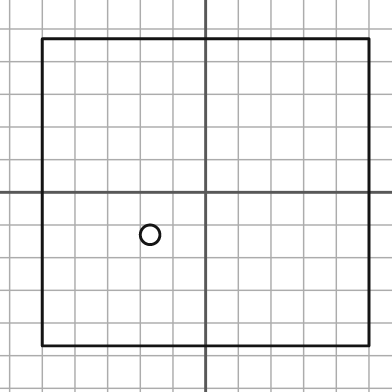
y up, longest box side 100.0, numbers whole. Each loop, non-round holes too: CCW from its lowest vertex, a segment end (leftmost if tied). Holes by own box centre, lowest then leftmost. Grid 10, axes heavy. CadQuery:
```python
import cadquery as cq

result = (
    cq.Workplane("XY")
    .moveTo(-50.0, -47.0)
    .lineTo(50.0, -47.0)
    .lineTo(50.0, 47.0)
    .lineTo(-50.0, 47.0)
    .close()
    .moveTo(-17.0, -13.0)
    .circle(3.0)
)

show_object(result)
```